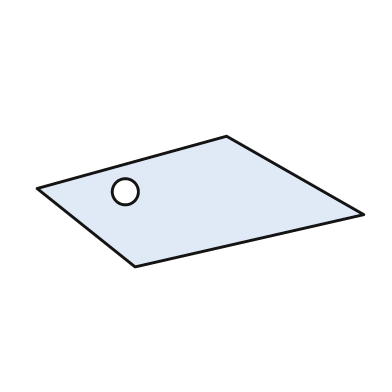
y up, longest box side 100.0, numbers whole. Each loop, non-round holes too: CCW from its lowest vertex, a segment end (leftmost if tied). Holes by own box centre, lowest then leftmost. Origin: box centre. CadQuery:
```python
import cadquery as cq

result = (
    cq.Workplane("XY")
    .moveTo(-20.0, -20.0)
    .lineTo(50.0, -4.0)
    .lineTo(8.0, 20.0)
    .lineTo(-50.0, 4.0)
    .close()
    .moveTo(-23.0, 3.0)
    .circle(4.0)
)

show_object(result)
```